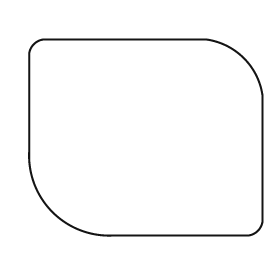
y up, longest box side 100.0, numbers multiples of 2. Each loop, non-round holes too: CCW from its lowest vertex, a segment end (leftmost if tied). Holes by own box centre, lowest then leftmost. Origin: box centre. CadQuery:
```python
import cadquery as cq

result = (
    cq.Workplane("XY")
    .moveTo(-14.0, -42.0)
    .lineTo(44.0, -42.0)
    .threePointArc((48.0, -40.0), (50.0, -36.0))
    .lineTo(50.0, 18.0)
    .threePointArc((42.0, 34.0), (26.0, 42.0))
    .lineTo(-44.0, 42.0)
    .threePointArc((-48.0, 40.0), (-50.0, 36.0))
    .lineTo(-50.0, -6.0)
    .threePointArc((-40.0, -32.0), (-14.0, -42.0))
    .close()
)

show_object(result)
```